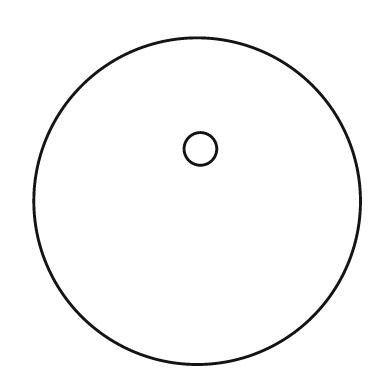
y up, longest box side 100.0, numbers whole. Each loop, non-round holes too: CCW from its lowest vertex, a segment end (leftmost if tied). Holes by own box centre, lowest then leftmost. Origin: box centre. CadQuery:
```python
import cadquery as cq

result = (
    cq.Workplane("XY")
    .moveTo(0.0, 0.0)
    .circle(50.0)
    .moveTo(1.0, 16.0)
    .circle(5.0)
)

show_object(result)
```